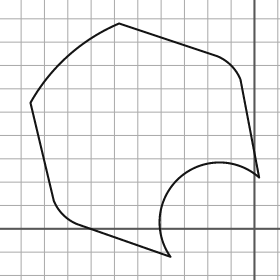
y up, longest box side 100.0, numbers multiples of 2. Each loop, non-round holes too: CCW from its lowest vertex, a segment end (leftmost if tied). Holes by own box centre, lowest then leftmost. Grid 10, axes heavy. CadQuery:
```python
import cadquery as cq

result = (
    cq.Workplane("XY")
    .moveTo(-36.0, -12.0)
    .threePointArc((-32.0, 22.0), (2.0, 22.0))
    .lineTo(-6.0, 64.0)
    .threePointArc((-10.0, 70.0), (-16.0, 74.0))
    .lineTo(-58.0, 88.0)
    .threePointArc((-80.0, 74.0), (-96.0, 54.0))
    .lineTo(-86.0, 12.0)
    .threePointArc((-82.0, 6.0), (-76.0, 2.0))
    .close()
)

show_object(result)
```